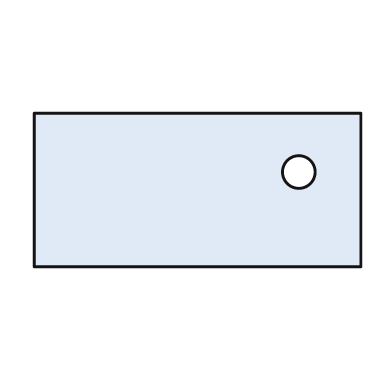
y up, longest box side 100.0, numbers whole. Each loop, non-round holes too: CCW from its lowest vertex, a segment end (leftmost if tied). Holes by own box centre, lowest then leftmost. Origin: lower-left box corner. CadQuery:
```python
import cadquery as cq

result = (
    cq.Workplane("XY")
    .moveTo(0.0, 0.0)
    .lineTo(100.0, 0.0)
    .lineTo(100.0, 47.0)
    .lineTo(0.0, 47.0)
    .close()
    .moveTo(81.0, 29.0)
    .circle(5.0)
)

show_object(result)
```